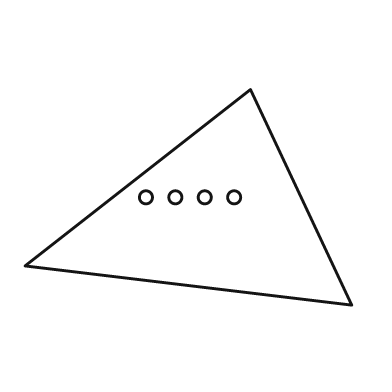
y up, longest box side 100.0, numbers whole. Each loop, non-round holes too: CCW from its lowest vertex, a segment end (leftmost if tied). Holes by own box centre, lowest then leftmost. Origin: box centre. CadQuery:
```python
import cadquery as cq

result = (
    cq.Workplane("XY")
    .moveTo(50.0, -33.0)
    .lineTo(19.0, 33.0)
    .lineTo(-50.0, -21.0)
    .close()
    .moveTo(-13.0, 0.0)
    .circle(2.0)
    .moveTo(-4.0, 0.0)
    .circle(2.0)
    .moveTo(5.0, 0.0)
    .circle(2.0)
    .moveTo(14.0, 0.0)
    .circle(2.0)
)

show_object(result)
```